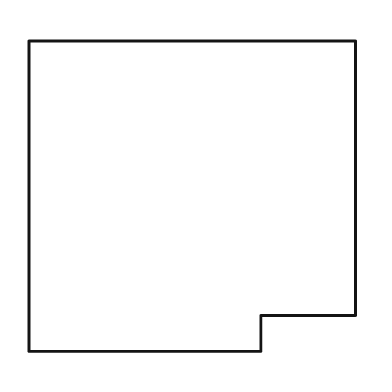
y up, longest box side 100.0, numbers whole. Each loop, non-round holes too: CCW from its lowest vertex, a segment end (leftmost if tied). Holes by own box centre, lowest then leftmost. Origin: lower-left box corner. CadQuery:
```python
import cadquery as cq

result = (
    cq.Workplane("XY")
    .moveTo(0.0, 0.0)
    .lineTo(71.0, 0.0)
    .lineTo(71.0, 11.0)
    .lineTo(100.0, 11.0)
    .lineTo(100.0, 95.0)
    .lineTo(0.0, 95.0)
    .close()
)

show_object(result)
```